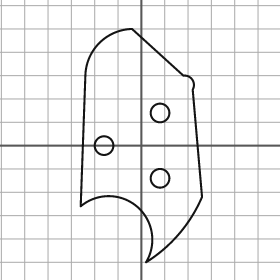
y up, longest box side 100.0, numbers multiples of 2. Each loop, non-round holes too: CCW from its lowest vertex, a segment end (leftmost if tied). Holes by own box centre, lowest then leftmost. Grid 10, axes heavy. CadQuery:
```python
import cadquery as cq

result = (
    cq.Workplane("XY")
    .moveTo(2.0, -50.0)
    .threePointArc((16.0, -38.0), (26.0, -22.0))
    .lineTo(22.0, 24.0)
    .threePointArc((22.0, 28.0), (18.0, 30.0))
    .lineTo(-4.0, 50.0)
    .threePointArc((-18.0, 44.0), (-24.0, 30.0))
    .lineTo(-26.0, -26.0)
    .threePointArc((-2.0, -26.0), (2.0, -50.0))
    .close()
    .moveTo(8.0, -14.0)
    .circle(4.0)
    .moveTo(-16.0, 0.0)
    .circle(4.0)
    .moveTo(8.0, 14.0)
    .circle(4.0)
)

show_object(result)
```